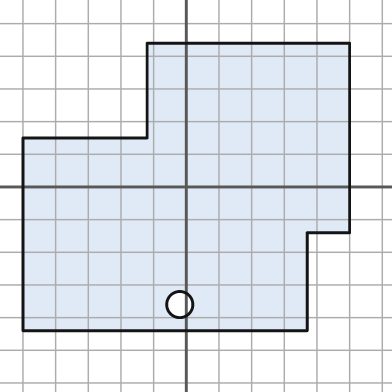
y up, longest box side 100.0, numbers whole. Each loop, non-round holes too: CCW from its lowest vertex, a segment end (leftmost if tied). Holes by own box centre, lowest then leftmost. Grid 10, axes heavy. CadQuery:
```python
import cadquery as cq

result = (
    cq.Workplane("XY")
    .moveTo(-50.0, -44.0)
    .lineTo(37.0, -44.0)
    .lineTo(37.0, -14.0)
    .lineTo(50.0, -14.0)
    .lineTo(50.0, 44.0)
    .lineTo(-12.0, 44.0)
    .lineTo(-12.0, 15.0)
    .lineTo(-50.0, 15.0)
    .close()
    .moveTo(-2.0, -36.0)
    .circle(4.0)
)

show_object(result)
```